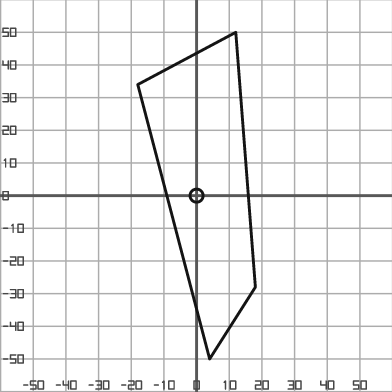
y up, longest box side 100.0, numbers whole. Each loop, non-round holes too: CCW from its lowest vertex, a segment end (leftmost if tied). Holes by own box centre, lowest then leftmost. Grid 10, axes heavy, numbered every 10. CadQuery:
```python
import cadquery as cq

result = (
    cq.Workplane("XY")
    .moveTo(4.0, -50.0)
    .lineTo(18.0, -28.0)
    .lineTo(12.0, 50.0)
    .lineTo(-18.0, 34.0)
    .close()
    .moveTo(0.0, 0.0)
    .circle(2.0)
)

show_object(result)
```